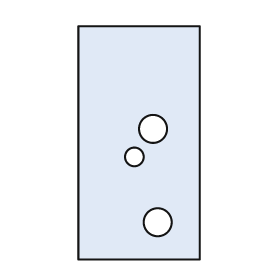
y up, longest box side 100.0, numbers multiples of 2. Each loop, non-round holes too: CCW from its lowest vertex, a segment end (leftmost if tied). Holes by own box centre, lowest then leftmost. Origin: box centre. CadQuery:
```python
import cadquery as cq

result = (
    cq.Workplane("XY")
    .moveTo(-26.0, -50.0)
    .lineTo(26.0, -50.0)
    .lineTo(26.0, 50.0)
    .lineTo(-26.0, 50.0)
    .close()
    .moveTo(8.0, -34.0)
    .circle(6.0)
    .moveTo(-2.0, -6.0)
    .circle(4.0)
    .moveTo(6.0, 6.0)
    .circle(6.0)
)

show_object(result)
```